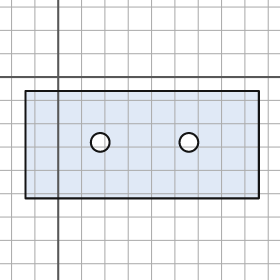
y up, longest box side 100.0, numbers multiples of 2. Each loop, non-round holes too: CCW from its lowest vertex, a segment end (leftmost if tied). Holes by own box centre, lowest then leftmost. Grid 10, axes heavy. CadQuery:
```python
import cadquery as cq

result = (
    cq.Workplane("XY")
    .moveTo(-14.0, -52.0)
    .lineTo(86.0, -52.0)
    .lineTo(86.0, -6.0)
    .lineTo(-14.0, -6.0)
    .close()
    .moveTo(18.0, -28.0)
    .circle(4.0)
    .moveTo(56.0, -28.0)
    .circle(4.0)
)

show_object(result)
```